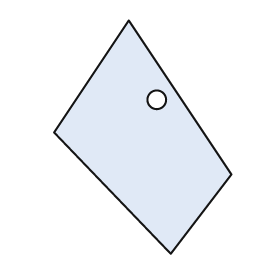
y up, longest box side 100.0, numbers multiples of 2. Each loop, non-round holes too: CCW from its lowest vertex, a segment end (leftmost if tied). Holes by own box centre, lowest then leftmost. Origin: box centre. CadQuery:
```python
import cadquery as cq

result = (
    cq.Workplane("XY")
    .moveTo(12.0, -50.0)
    .lineTo(38.0, -16.0)
    .lineTo(-6.0, 50.0)
    .lineTo(-38.0, 2.0)
    .close()
    .moveTo(6.0, 16.0)
    .circle(4.0)
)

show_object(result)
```